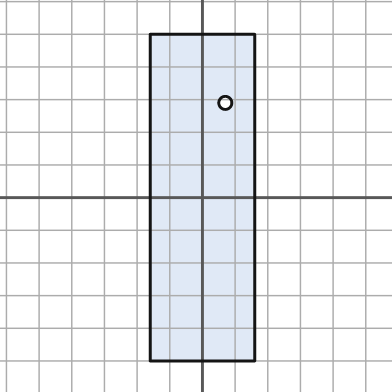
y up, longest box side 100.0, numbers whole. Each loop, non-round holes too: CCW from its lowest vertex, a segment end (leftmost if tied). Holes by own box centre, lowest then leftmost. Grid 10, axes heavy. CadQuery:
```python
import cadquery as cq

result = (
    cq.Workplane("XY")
    .moveTo(-16.0, -50.0)
    .lineTo(16.0, -50.0)
    .lineTo(16.0, 50.0)
    .lineTo(-16.0, 50.0)
    .close()
    .moveTo(7.0, 29.0)
    .circle(2.0)
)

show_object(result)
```